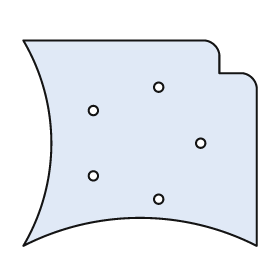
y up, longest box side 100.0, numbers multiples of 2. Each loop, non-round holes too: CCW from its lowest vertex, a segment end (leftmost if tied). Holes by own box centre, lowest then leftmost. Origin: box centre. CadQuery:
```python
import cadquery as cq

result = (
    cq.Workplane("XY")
    .moveTo(-50.0, -44.0)
    .threePointArc((0.0, -32.0), (50.0, -44.0))
    .lineTo(50.0, 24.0)
    .threePointArc((48.0, 28.0), (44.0, 30.0))
    .lineTo(34.0, 30.0)
    .lineTo(34.0, 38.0)
    .threePointArc((32.0, 42.0), (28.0, 44.0))
    .lineTo(-50.0, 44.0)
    .threePointArc((-38.0, 0.0), (-50.0, -44.0))
    .close()
    .moveTo(8.0, -24.0)
    .circle(2.0)
    .moveTo(-20.0, -14.0)
    .circle(2.0)
    .moveTo(26.0, 0.0)
    .circle(2.0)
    .moveTo(-20.0, 14.0)
    .circle(2.0)
    .moveTo(8.0, 24.0)
    .circle(2.0)
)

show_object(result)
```